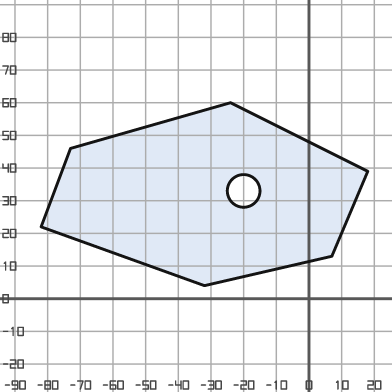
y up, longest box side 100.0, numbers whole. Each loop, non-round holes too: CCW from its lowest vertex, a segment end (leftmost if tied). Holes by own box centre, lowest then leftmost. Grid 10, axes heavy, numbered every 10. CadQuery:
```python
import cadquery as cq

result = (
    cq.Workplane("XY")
    .moveTo(-32.0, 4.0)
    .lineTo(7.0, 13.0)
    .lineTo(18.0, 39.0)
    .lineTo(-24.0, 60.0)
    .lineTo(-73.0, 46.0)
    .lineTo(-82.0, 22.0)
    .close()
    .moveTo(-20.0, 33.0)
    .circle(5.0)
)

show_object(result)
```